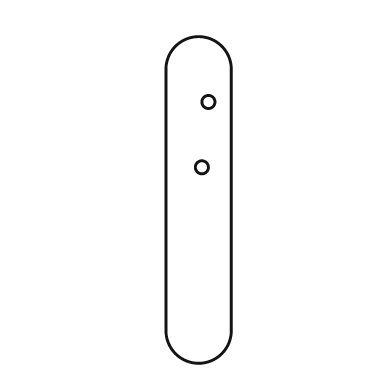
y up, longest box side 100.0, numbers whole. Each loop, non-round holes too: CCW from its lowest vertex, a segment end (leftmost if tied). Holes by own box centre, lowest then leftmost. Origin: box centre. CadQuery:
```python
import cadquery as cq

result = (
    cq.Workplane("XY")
    .moveTo(-10.0, -40.0)
    .threePointArc((0.0, -50.0), (10.0, -40.0))
    .lineTo(10.0, 40.0)
    .threePointArc((0.0, 50.0), (-10.0, 40.0))
    .close()
    .moveTo(1.0, 10.0)
    .circle(2.0)
    .moveTo(3.0, 30.0)
    .circle(2.0)
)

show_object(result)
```